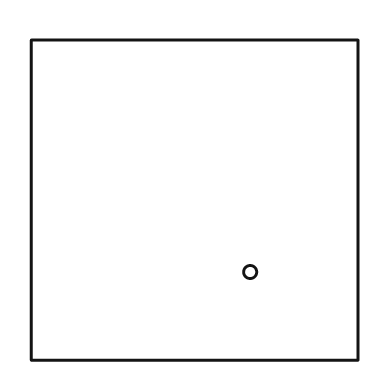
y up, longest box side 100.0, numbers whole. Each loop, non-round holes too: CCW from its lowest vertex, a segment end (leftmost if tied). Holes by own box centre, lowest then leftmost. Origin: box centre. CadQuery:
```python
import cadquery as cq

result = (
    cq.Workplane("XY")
    .moveTo(-50.0, -49.0)
    .lineTo(50.0, -49.0)
    .lineTo(50.0, 49.0)
    .lineTo(-50.0, 49.0)
    .close()
    .moveTo(17.0, -22.0)
    .circle(2.0)
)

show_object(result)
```